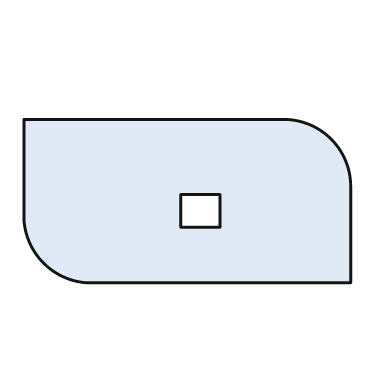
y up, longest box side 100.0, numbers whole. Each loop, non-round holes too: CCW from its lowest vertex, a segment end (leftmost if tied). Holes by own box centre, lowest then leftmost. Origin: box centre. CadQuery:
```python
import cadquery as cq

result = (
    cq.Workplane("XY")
    .moveTo(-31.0, -25.0)
    .lineTo(50.0, -25.0)
    .lineTo(50.0, 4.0)
    .threePointArc((44.0, 19.0), (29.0, 25.0))
    .lineTo(-50.0, 25.0)
    .lineTo(-50.0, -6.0)
    .threePointArc((-44.0, -19.0), (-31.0, -25.0))
    .close()
    .moveTo(-2.0, -8.0)
    .lineTo(10.0, -8.0)
    .lineTo(10.0, 2.0)
    .lineTo(-2.0, 2.0)
    .close()
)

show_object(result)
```